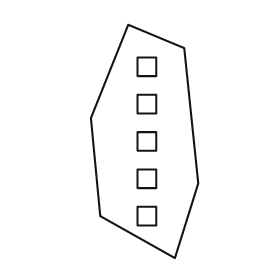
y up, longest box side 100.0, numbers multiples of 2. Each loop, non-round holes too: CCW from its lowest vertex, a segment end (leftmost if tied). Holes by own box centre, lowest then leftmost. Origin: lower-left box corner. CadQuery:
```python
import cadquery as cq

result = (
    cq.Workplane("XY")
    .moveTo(36.0, 0.0)
    .lineTo(46.0, 32.0)
    .lineTo(40.0, 90.0)
    .lineTo(16.0, 100.0)
    .lineTo(0.0, 60.0)
    .lineTo(4.0, 18.0)
    .close()
    .moveTo(20.0, 14.0)
    .lineTo(28.0, 14.0)
    .lineTo(28.0, 22.0)
    .lineTo(20.0, 22.0)
    .close()
    .moveTo(20.0, 30.0)
    .lineTo(28.0, 30.0)
    .lineTo(28.0, 38.0)
    .lineTo(20.0, 38.0)
    .close()
    .moveTo(20.0, 46.0)
    .lineTo(28.0, 46.0)
    .lineTo(28.0, 54.0)
    .lineTo(20.0, 54.0)
    .close()
    .moveTo(20.0, 62.0)
    .lineTo(28.0, 62.0)
    .lineTo(28.0, 70.0)
    .lineTo(20.0, 70.0)
    .close()
    .moveTo(20.0, 78.0)
    .lineTo(28.0, 78.0)
    .lineTo(28.0, 86.0)
    .lineTo(20.0, 86.0)
    .close()
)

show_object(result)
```